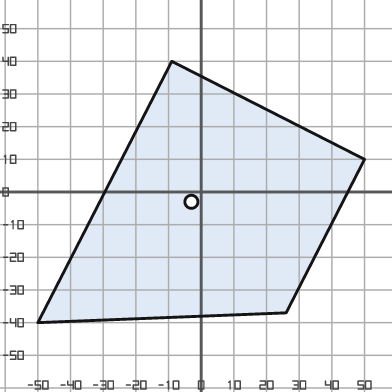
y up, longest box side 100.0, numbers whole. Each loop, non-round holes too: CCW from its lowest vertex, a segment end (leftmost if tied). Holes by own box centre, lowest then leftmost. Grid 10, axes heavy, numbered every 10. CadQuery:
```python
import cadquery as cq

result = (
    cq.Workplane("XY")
    .moveTo(-50.0, -40.0)
    .lineTo(26.0, -37.0)
    .lineTo(50.0, 10.0)
    .lineTo(-9.0, 40.0)
    .close()
    .moveTo(-3.0, -3.0)
    .circle(2.0)
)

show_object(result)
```